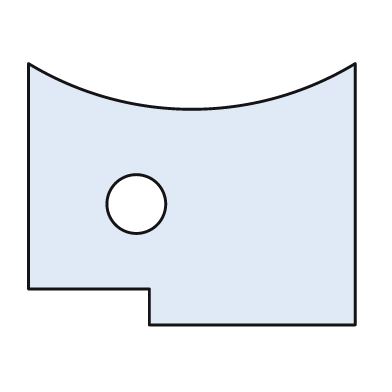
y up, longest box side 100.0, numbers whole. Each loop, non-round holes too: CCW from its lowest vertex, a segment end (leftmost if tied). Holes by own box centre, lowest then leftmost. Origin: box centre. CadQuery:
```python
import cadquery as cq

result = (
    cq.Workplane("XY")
    .moveTo(-13.0, -40.0)
    .lineTo(50.0, -40.0)
    .lineTo(50.0, 40.0)
    .threePointArc((0.0, 26.0), (-50.0, 40.0))
    .lineTo(-50.0, -29.0)
    .lineTo(-13.0, -29.0)
    .close()
    .moveTo(-17.0, -3.0)
    .circle(9.0)
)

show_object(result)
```